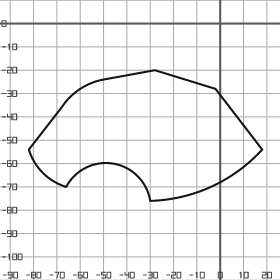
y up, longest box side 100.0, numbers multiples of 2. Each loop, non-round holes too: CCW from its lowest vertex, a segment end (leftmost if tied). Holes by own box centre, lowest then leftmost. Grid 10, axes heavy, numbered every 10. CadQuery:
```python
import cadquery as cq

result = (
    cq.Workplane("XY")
    .moveTo(-30.0, -76.0)
    .threePointArc((-4.0, -70.0), (18.0, -54.0))
    .lineTo(-2.0, -28.0)
    .lineTo(-28.0, -20.0)
    .lineTo(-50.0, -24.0)
    .threePointArc((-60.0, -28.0), (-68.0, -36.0))
    .lineTo(-82.0, -54.0)
    .threePointArc((-76.0, -64.0), (-66.0, -70.0))
    .threePointArc((-46.0, -60.0), (-30.0, -76.0))
    .close()
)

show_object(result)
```